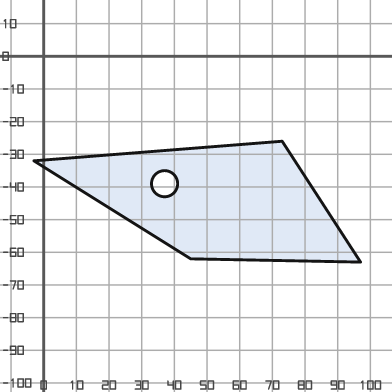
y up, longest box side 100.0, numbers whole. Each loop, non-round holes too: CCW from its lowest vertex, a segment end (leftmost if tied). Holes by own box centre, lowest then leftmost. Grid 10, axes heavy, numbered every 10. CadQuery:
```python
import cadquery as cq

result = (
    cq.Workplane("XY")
    .moveTo(97.0, -63.0)
    .lineTo(73.0, -26.0)
    .lineTo(-3.0, -32.0)
    .lineTo(45.0, -62.0)
    .close()
    .moveTo(37.0, -39.0)
    .circle(4.0)
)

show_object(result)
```